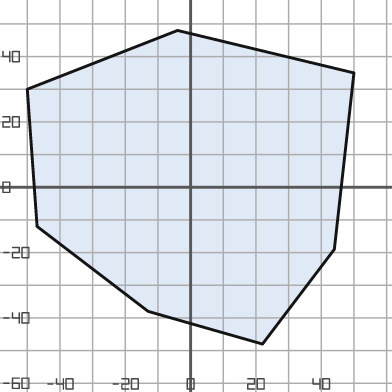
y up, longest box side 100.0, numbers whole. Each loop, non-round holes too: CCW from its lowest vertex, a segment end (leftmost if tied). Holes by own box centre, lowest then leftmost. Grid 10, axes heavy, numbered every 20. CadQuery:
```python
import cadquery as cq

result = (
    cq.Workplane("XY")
    .moveTo(22.0, -48.0)
    .lineTo(44.0, -19.0)
    .lineTo(50.0, 35.0)
    .lineTo(-4.0, 48.0)
    .lineTo(-50.0, 30.0)
    .lineTo(-47.0, -12.0)
    .lineTo(-13.0, -38.0)
    .close()
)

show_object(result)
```